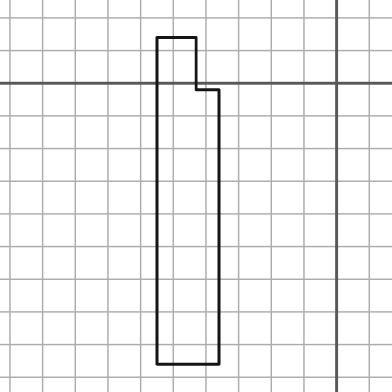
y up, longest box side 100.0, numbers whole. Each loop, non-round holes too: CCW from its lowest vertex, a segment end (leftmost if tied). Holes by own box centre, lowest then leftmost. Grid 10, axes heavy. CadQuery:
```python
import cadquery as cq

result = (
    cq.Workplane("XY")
    .moveTo(-55.0, -86.0)
    .lineTo(-36.0, -86.0)
    .lineTo(-36.0, -2.0)
    .lineTo(-43.0, -2.0)
    .lineTo(-43.0, 14.0)
    .lineTo(-55.0, 14.0)
    .close()
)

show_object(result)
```